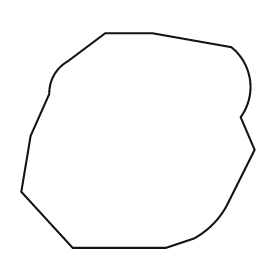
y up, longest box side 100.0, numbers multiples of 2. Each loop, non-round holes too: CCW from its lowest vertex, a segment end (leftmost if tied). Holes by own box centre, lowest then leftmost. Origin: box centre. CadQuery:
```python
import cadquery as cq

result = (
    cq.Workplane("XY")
    .moveTo(-28.0, -46.0)
    .lineTo(12.0, -46.0)
    .lineTo(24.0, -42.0)
    .threePointArc((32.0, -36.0), (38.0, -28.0))
    .lineTo(50.0, -4.0)
    .lineTo(44.0, 10.0)
    .threePointArc((48.0, 26.0), (40.0, 40.0))
    .lineTo(6.0, 46.0)
    .lineTo(-14.0, 46.0)
    .lineTo(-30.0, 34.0)
    .threePointArc((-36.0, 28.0), (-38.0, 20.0))
    .lineTo(-46.0, 2.0)
    .lineTo(-50.0, -22.0)
    .close()
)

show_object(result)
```